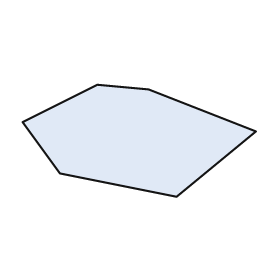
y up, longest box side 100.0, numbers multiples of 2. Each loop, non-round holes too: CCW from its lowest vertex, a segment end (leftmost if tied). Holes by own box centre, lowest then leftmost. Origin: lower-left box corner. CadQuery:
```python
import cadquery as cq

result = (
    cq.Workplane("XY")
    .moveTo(66.0, 0.0)
    .lineTo(100.0, 28.0)
    .lineTo(54.0, 46.0)
    .lineTo(32.0, 48.0)
    .lineTo(0.0, 32.0)
    .lineTo(16.0, 10.0)
    .close()
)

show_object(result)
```